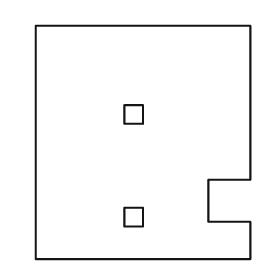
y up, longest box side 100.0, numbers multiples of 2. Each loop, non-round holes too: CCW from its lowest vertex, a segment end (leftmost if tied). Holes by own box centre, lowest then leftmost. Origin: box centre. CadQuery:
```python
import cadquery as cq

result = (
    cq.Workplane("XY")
    .moveTo(-46.0, -50.0)
    .lineTo(46.0, -50.0)
    .lineTo(46.0, -34.0)
    .lineTo(28.0, -34.0)
    .lineTo(28.0, -16.0)
    .lineTo(46.0, -16.0)
    .lineTo(46.0, 50.0)
    .lineTo(-46.0, 50.0)
    .close()
    .moveTo(-8.0, -36.0)
    .lineTo(0.0, -36.0)
    .lineTo(0.0, -28.0)
    .lineTo(-8.0, -28.0)
    .close()
    .moveTo(-8.0, 8.0)
    .lineTo(0.0, 8.0)
    .lineTo(0.0, 16.0)
    .lineTo(-8.0, 16.0)
    .close()
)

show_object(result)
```